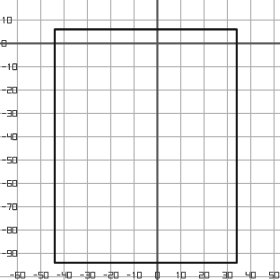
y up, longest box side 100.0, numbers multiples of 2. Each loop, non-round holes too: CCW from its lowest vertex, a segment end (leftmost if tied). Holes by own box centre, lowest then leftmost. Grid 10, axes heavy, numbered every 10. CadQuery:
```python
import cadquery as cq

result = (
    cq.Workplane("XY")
    .moveTo(-44.0, -94.0)
    .lineTo(34.0, -94.0)
    .lineTo(34.0, 6.0)
    .lineTo(-44.0, 6.0)
    .close()
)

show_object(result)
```